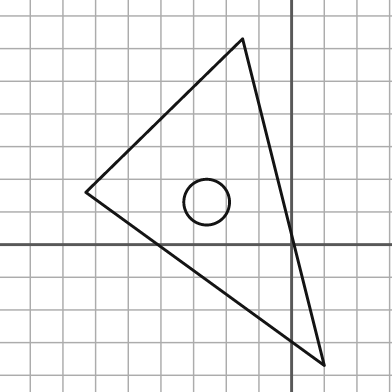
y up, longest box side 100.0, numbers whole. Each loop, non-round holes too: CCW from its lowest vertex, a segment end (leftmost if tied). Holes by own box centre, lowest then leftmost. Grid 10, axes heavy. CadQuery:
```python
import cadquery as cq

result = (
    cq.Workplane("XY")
    .moveTo(10.0, -37.0)
    .lineTo(-15.0, 63.0)
    .lineTo(-63.0, 16.0)
    .close()
    .moveTo(-26.0, 13.0)
    .circle(7.0)
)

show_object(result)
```